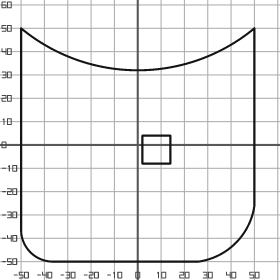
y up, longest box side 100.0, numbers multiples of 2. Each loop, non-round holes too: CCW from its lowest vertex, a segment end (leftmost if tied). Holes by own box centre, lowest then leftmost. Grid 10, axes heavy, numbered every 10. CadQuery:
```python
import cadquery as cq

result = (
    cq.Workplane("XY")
    .moveTo(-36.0, -50.0)
    .lineTo(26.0, -50.0)
    .threePointArc((42.0, -42.0), (50.0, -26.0))
    .lineTo(50.0, 50.0)
    .threePointArc((0.0, 32.0), (-50.0, 50.0))
    .lineTo(-50.0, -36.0)
    .threePointArc((-46.0, -46.0), (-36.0, -50.0))
    .close()
    .moveTo(2.0, -8.0)
    .lineTo(14.0, -8.0)
    .lineTo(14.0, 4.0)
    .lineTo(2.0, 4.0)
    .close()
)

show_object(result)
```